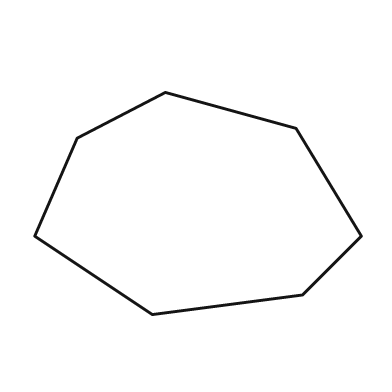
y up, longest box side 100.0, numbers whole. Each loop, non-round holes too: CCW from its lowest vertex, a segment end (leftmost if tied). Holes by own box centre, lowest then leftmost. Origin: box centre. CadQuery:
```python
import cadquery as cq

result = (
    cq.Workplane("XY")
    .moveTo(-14.0, -34.0)
    .lineTo(32.0, -28.0)
    .lineTo(50.0, -10.0)
    .lineTo(30.0, 23.0)
    .lineTo(-10.0, 34.0)
    .lineTo(-37.0, 20.0)
    .lineTo(-50.0, -10.0)
    .close()
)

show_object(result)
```